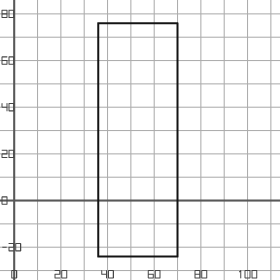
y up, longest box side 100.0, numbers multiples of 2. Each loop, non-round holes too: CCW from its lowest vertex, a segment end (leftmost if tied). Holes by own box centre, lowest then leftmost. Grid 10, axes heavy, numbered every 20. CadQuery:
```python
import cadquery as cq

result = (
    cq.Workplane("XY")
    .moveTo(36.0, -24.0)
    .lineTo(70.0, -24.0)
    .lineTo(70.0, 76.0)
    .lineTo(36.0, 76.0)
    .close()
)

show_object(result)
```